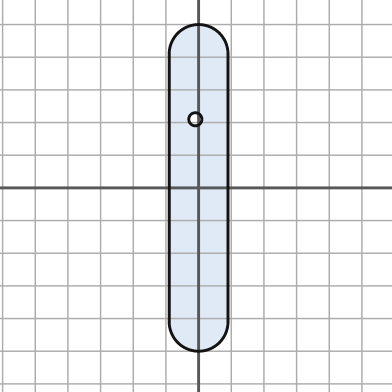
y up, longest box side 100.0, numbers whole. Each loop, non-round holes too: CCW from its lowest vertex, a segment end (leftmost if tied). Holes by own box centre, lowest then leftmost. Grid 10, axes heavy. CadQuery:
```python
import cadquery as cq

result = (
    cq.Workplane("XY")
    .moveTo(-9.0, -41.0)
    .threePointArc((0.0, -50.0), (9.0, -41.0))
    .lineTo(9.0, 41.0)
    .threePointArc((0.0, 50.0), (-9.0, 41.0))
    .close()
    .moveTo(-1.0, 21.0)
    .circle(2.0)
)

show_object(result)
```